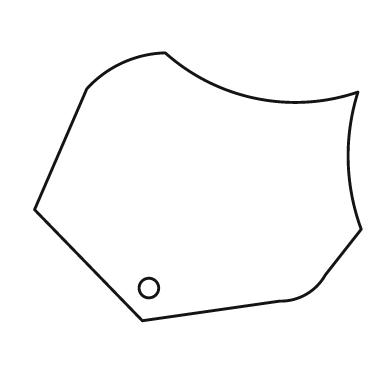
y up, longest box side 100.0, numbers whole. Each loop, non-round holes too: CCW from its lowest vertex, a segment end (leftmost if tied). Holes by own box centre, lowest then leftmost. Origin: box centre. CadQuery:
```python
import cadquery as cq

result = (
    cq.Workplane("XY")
    .moveTo(-17.0, -41.0)
    .lineTo(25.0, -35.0)
    .threePointArc((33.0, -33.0), (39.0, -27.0))
    .lineTo(50.0, -13.0)
    .threePointArc((46.0, 8.0), (49.0, 29.0))
    .threePointArc((18.0, 27.0), (-10.0, 41.0))
    .threePointArc((-23.0, 38.0), (-34.0, 30.0))
    .lineTo(-50.0, -7.0)
    .close()
    .moveTo(-15.0, -31.0)
    .circle(3.0)
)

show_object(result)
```